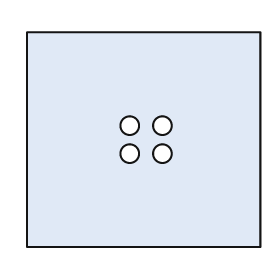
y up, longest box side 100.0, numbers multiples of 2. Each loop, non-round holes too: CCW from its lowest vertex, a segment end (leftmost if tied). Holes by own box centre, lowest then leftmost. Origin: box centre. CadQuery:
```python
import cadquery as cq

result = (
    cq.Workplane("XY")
    .moveTo(-50.0, -46.0)
    .lineTo(50.0, -46.0)
    .lineTo(50.0, 46.0)
    .lineTo(-50.0, 46.0)
    .close()
    .moveTo(-6.0, -6.0)
    .circle(4.0)
    .moveTo(8.0, -6.0)
    .circle(4.0)
    .moveTo(-6.0, 6.0)
    .circle(4.0)
    .moveTo(8.0, 6.0)
    .circle(4.0)
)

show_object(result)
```